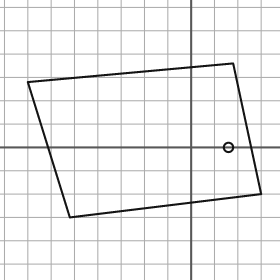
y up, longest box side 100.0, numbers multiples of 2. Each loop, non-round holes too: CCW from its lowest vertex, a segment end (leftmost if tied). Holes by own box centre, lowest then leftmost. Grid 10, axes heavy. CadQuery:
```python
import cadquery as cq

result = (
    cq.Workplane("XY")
    .moveTo(-52.0, -30.0)
    .lineTo(30.0, -20.0)
    .lineTo(18.0, 36.0)
    .lineTo(-70.0, 28.0)
    .close()
    .moveTo(16.0, 0.0)
    .circle(2.0)
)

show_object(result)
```